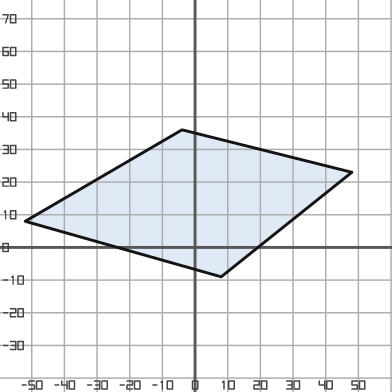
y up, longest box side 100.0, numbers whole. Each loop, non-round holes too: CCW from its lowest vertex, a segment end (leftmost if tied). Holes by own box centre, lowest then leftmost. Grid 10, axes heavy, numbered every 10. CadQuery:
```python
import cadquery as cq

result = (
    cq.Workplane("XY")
    .moveTo(8.0, -9.0)
    .lineTo(48.0, 23.0)
    .lineTo(-4.0, 36.0)
    .lineTo(-52.0, 8.0)
    .close()
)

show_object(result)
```